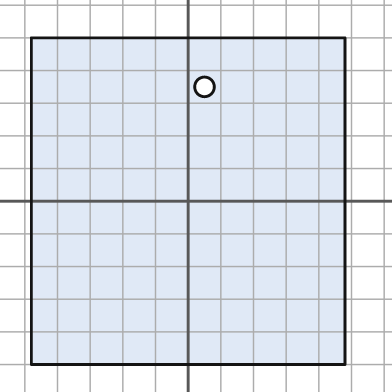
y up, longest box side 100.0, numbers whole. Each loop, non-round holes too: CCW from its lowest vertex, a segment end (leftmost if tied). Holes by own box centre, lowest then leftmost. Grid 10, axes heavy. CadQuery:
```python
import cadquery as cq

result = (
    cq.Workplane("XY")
    .moveTo(-48.0, -50.0)
    .lineTo(48.0, -50.0)
    .lineTo(48.0, 50.0)
    .lineTo(-48.0, 50.0)
    .close()
    .moveTo(5.0, 35.0)
    .circle(3.0)
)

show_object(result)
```